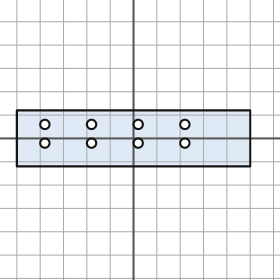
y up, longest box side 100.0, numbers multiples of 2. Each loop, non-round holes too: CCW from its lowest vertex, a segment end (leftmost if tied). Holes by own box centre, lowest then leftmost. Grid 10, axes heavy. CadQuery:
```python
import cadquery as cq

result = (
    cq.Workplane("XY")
    .moveTo(-50.0, -12.0)
    .lineTo(50.0, -12.0)
    .lineTo(50.0, 12.0)
    .lineTo(-50.0, 12.0)
    .close()
    .moveTo(-38.0, -2.0)
    .circle(2.0)
    .moveTo(-18.0, -2.0)
    .circle(2.0)
    .moveTo(2.0, -2.0)
    .circle(2.0)
    .moveTo(22.0, -2.0)
    .circle(2.0)
    .moveTo(-38.0, 6.0)
    .circle(2.0)
    .moveTo(-18.0, 6.0)
    .circle(2.0)
    .moveTo(2.0, 6.0)
    .circle(2.0)
    .moveTo(22.0, 6.0)
    .circle(2.0)
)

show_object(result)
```